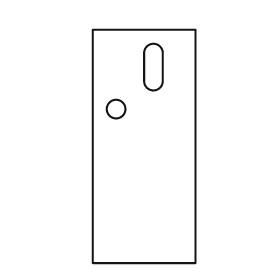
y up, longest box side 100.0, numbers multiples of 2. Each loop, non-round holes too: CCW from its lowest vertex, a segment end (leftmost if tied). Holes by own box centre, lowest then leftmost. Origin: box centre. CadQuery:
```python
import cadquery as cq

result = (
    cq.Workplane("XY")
    .moveTo(-22.0, -50.0)
    .lineTo(22.0, -50.0)
    .lineTo(22.0, 50.0)
    .lineTo(-22.0, 50.0)
    .close()
    .moveTo(-12.0, 16.0)
    .circle(4.0)
    .moveTo(0.0, 28.0)
    .threePointArc((4.0, 24.0), (8.0, 28.0))
    .lineTo(8.0, 40.0)
    .threePointArc((4.0, 44.0), (0.0, 40.0))
    .close()
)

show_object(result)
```